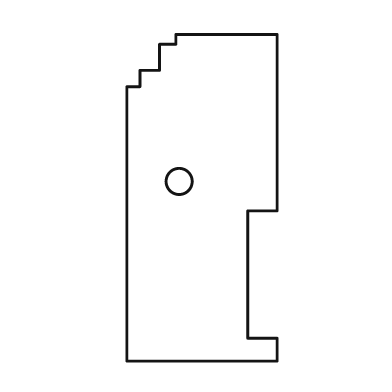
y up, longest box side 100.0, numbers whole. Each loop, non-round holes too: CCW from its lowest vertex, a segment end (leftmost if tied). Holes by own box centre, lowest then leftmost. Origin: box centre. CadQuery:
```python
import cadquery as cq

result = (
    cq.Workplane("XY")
    .moveTo(-23.0, -50.0)
    .lineTo(23.0, -50.0)
    .lineTo(23.0, -43.0)
    .lineTo(14.0, -43.0)
    .lineTo(14.0, -4.0)
    .lineTo(23.0, -4.0)
    .lineTo(23.0, 50.0)
    .lineTo(-8.0, 50.0)
    .lineTo(-8.0, 47.0)
    .lineTo(-13.0, 47.0)
    .lineTo(-13.0, 39.0)
    .lineTo(-19.0, 39.0)
    .lineTo(-19.0, 34.0)
    .lineTo(-23.0, 34.0)
    .close()
    .moveTo(-7.0, 5.0)
    .circle(4.0)
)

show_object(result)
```